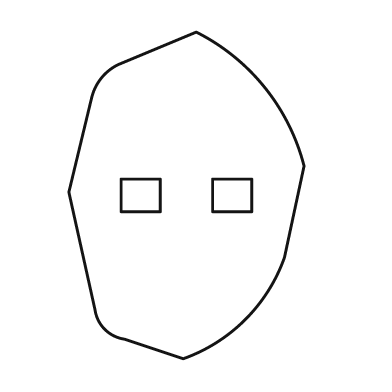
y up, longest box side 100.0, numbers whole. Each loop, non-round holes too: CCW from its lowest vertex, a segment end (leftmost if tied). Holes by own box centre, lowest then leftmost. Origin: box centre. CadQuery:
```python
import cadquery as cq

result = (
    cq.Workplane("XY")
    .moveTo(-1.0, -50.0)
    .threePointArc((18.0, -38.0), (30.0, -19.0))
    .lineTo(36.0, 9.0)
    .threePointArc((24.0, 33.0), (3.0, 50.0))
    .lineTo(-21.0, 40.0)
    .threePointArc((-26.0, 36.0), (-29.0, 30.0))
    .lineTo(-36.0, 1.0)
    .lineTo(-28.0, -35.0)
    .threePointArc((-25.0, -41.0), (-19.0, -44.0))
    .close()
    .moveTo(-20.0, -5.0)
    .lineTo(-8.0, -5.0)
    .lineTo(-8.0, 5.0)
    .lineTo(-20.0, 5.0)
    .close()
    .moveTo(8.0, -5.0)
    .lineTo(20.0, -5.0)
    .lineTo(20.0, 5.0)
    .lineTo(8.0, 5.0)
    .close()
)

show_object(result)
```